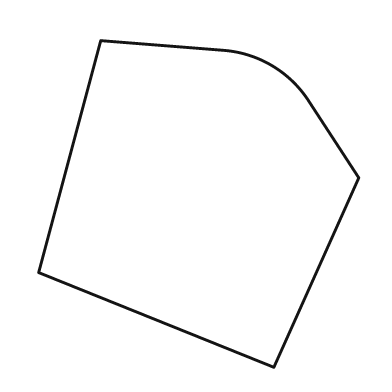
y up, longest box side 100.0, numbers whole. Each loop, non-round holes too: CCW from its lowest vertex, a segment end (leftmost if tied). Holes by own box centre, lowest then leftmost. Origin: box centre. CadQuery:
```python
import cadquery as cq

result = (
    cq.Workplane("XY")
    .moveTo(23.0, -50.0)
    .lineTo(49.0, 8.0)
    .lineTo(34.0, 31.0)
    .threePointArc((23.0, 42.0), (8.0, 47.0))
    .lineTo(-30.0, 50.0)
    .lineTo(-49.0, -21.0)
    .close()
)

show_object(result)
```